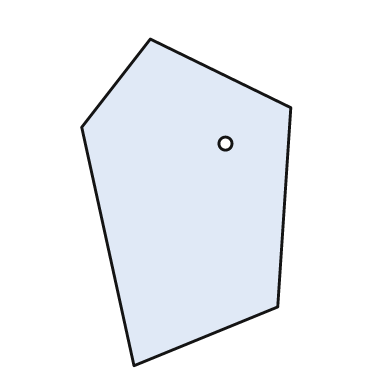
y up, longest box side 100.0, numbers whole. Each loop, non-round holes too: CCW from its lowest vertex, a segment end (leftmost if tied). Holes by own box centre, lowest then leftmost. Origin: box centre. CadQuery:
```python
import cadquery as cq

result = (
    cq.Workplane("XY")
    .moveTo(-16.0, -50.0)
    .lineTo(28.0, -32.0)
    .lineTo(32.0, 29.0)
    .lineTo(-11.0, 50.0)
    .lineTo(-32.0, 23.0)
    .close()
    .moveTo(12.0, 18.0)
    .circle(2.0)
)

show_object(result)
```